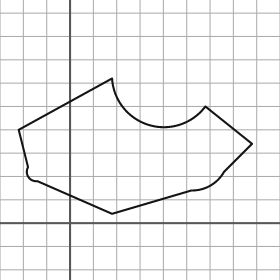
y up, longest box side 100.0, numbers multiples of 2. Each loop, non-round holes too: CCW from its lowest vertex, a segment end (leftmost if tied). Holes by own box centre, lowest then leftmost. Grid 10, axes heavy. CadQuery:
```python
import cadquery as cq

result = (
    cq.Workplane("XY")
    .moveTo(18.0, 4.0)
    .lineTo(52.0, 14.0)
    .threePointArc((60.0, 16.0), (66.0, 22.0))
    .lineTo(78.0, 34.0)
    .lineTo(58.0, 50.0)
    .threePointArc((34.0, 42.0), (18.0, 62.0))
    .lineTo(-22.0, 40.0)
    .lineTo(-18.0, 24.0)
    .threePointArc((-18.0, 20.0), (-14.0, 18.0))
    .close()
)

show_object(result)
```